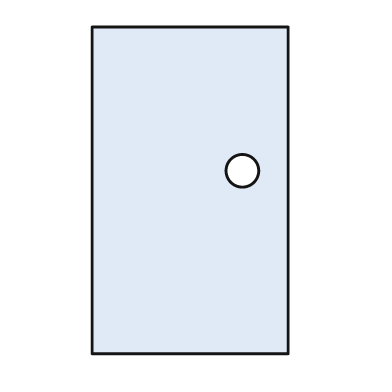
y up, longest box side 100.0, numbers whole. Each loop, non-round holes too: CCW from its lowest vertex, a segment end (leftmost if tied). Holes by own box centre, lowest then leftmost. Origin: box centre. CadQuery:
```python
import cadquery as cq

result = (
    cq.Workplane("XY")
    .moveTo(-30.0, -50.0)
    .lineTo(30.0, -50.0)
    .lineTo(30.0, 50.0)
    .lineTo(-30.0, 50.0)
    .close()
    .moveTo(16.0, 6.0)
    .circle(5.0)
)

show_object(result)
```